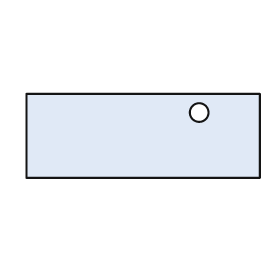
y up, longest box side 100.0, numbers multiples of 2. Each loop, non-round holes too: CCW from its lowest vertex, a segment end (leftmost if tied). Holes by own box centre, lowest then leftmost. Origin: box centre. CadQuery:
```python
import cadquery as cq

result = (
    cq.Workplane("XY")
    .moveTo(-50.0, -18.0)
    .lineTo(50.0, -18.0)
    .lineTo(50.0, 18.0)
    .lineTo(-50.0, 18.0)
    .close()
    .moveTo(24.0, 10.0)
    .circle(4.0)
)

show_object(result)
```